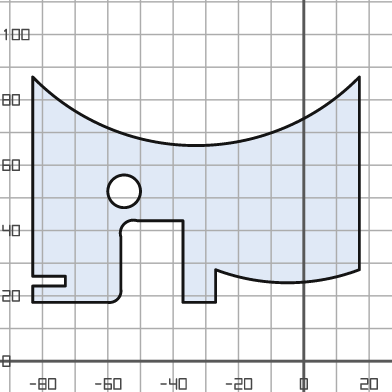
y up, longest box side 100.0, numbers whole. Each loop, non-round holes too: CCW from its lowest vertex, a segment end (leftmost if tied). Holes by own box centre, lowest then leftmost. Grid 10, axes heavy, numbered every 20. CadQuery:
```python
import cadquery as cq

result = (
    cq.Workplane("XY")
    .moveTo(-83.0, 18.0)
    .lineTo(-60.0, 18.0)
    .threePointArc((-57.0, 19.0), (-56.0, 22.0))
    .lineTo(-56.0, 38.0)
    .threePointArc((-55.0, 42.0), (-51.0, 43.0))
    .lineTo(-37.0, 43.0)
    .lineTo(-37.0, 18.0)
    .lineTo(-27.0, 18.0)
    .lineTo(-27.0, 28.0)
    .threePointArc((-5.0, 24.0), (17.0, 28.0))
    .lineTo(17.0, 87.0)
    .threePointArc((-33.0, 66.0), (-83.0, 87.0))
    .lineTo(-83.0, 26.0)
    .lineTo(-73.0, 26.0)
    .lineTo(-73.0, 23.0)
    .lineTo(-83.0, 23.0)
    .close()
    .moveTo(-55.0, 52.0)
    .circle(5.0)
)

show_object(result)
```